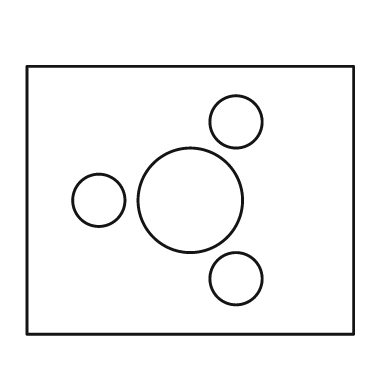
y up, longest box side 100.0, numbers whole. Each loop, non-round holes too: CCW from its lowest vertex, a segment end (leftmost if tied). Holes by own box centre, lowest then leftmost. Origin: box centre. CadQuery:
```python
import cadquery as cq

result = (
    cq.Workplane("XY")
    .moveTo(-50.0, -41.0)
    .lineTo(50.0, -41.0)
    .lineTo(50.0, 41.0)
    .lineTo(-50.0, 41.0)
    .close()
    .moveTo(14.0, -24.0)
    .circle(8.0)
    .moveTo(-28.0, 0.0)
    .circle(8.0)
    .moveTo(0.0, 0.0)
    .circle(16.0)
    .moveTo(14.0, 24.0)
    .circle(8.0)
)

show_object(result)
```